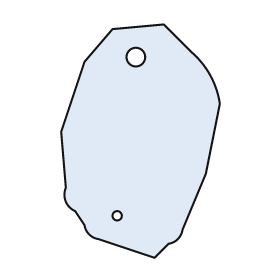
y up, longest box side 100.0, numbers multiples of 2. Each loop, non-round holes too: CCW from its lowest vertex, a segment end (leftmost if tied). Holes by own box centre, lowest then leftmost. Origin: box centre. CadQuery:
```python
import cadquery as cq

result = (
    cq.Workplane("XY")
    .moveTo(6.0, -50.0)
    .lineTo(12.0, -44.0)
    .threePointArc((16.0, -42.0), (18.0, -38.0))
    .lineTo(28.0, -14.0)
    .lineTo(34.0, 16.0)
    .threePointArc((30.0, 28.0), (22.0, 38.0))
    .lineTo(10.0, 50.0)
    .lineTo(-12.0, 48.0)
    .lineTo(-24.0, 34.0)
    .lineTo(-34.0, 4.0)
    .lineTo(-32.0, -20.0)
    .threePointArc((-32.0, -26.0), (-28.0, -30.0))
    .lineTo(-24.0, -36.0)
    .threePointArc((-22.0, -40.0), (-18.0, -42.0))
    .close()
    .moveTo(-10.0, -32.0)
    .circle(2.0)
    .moveTo(-2.0, 36.0)
    .circle(4.0)
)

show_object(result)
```